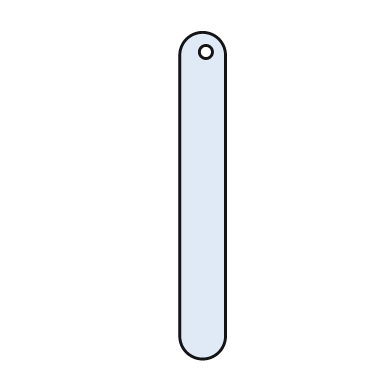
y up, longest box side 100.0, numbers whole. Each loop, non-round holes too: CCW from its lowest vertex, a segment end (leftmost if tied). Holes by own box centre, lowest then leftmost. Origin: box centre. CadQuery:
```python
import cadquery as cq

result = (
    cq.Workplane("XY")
    .moveTo(-7.0, -43.0)
    .threePointArc((0.0, -50.0), (7.0, -43.0))
    .lineTo(7.0, 43.0)
    .threePointArc((0.0, 50.0), (-7.0, 43.0))
    .close()
    .moveTo(1.0, 44.0)
    .circle(2.0)
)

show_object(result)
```